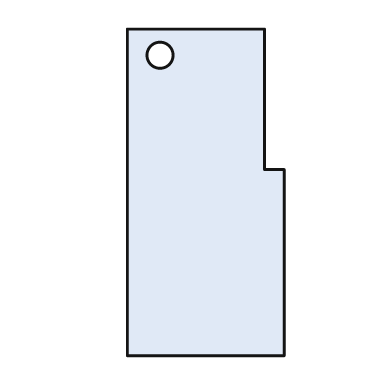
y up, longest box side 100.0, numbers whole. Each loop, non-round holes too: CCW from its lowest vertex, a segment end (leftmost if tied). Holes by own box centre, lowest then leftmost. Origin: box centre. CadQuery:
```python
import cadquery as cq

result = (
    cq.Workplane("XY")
    .moveTo(-24.0, -50.0)
    .lineTo(24.0, -50.0)
    .lineTo(24.0, 7.0)
    .lineTo(18.0, 7.0)
    .lineTo(18.0, 50.0)
    .lineTo(-24.0, 50.0)
    .close()
    .moveTo(-14.0, 42.0)
    .circle(4.0)
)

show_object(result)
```